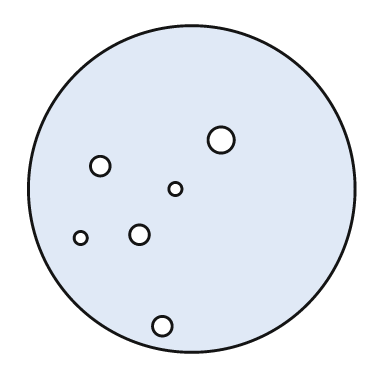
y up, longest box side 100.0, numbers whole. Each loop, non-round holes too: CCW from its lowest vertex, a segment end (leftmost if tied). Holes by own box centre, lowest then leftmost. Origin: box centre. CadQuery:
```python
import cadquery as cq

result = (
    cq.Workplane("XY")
    .moveTo(0.0, 0.0)
    .circle(50.0)
    .moveTo(-9.0, -42.0)
    .circle(3.0)
    .moveTo(-34.0, -15.0)
    .circle(2.0)
    .moveTo(-16.0, -14.0)
    .circle(3.0)
    .moveTo(-5.0, 0.0)
    .circle(2.0)
    .moveTo(-28.0, 7.0)
    .circle(3.0)
    .moveTo(9.0, 15.0)
    .circle(4.0)
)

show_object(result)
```